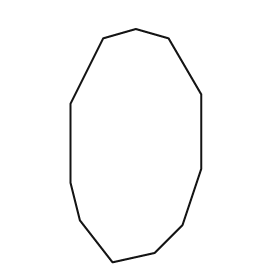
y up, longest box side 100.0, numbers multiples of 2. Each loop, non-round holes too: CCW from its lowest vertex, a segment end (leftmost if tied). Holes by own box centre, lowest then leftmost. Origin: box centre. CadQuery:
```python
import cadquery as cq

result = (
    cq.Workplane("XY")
    .moveTo(-10.0, -50.0)
    .lineTo(8.0, -46.0)
    .lineTo(20.0, -34.0)
    .lineTo(28.0, -10.0)
    .lineTo(28.0, 22.0)
    .lineTo(14.0, 46.0)
    .lineTo(0.0, 50.0)
    .lineTo(-14.0, 46.0)
    .lineTo(-28.0, 18.0)
    .lineTo(-28.0, -16.0)
    .lineTo(-24.0, -32.0)
    .close()
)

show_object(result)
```